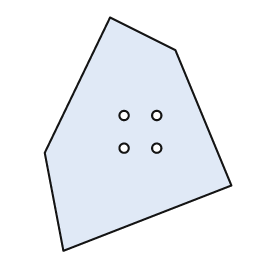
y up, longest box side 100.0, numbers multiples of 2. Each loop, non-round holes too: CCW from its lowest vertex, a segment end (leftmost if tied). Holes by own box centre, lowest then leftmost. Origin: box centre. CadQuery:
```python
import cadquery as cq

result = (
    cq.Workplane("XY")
    .moveTo(-32.0, -50.0)
    .lineTo(40.0, -22.0)
    .lineTo(16.0, 36.0)
    .lineTo(-12.0, 50.0)
    .lineTo(-40.0, -8.0)
    .close()
    .moveTo(-6.0, -6.0)
    .circle(2.0)
    .moveTo(8.0, -6.0)
    .circle(2.0)
    .moveTo(-6.0, 8.0)
    .circle(2.0)
    .moveTo(8.0, 8.0)
    .circle(2.0)
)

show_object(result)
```